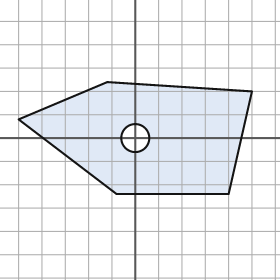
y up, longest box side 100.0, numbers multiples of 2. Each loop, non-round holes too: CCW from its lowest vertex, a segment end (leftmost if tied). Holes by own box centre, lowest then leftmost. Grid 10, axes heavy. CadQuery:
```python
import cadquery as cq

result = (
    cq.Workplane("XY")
    .moveTo(-8.0, -24.0)
    .lineTo(40.0, -24.0)
    .lineTo(50.0, 20.0)
    .lineTo(-12.0, 24.0)
    .lineTo(-50.0, 8.0)
    .close()
    .moveTo(0.0, 0.0)
    .circle(6.0)
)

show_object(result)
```